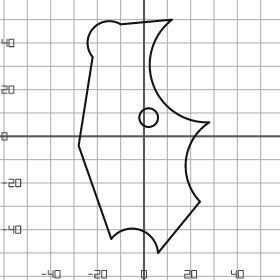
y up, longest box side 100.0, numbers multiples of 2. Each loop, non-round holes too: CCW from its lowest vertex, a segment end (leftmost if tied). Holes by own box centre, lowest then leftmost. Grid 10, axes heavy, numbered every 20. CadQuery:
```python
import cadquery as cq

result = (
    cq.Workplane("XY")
    .moveTo(6.0, -50.0)
    .lineTo(24.0, -28.0)
    .threePointArc((18.0, -10.0), (28.0, 6.0))
    .threePointArc((4.0, 22.0), (12.0, 50.0))
    .lineTo(-10.0, 48.0)
    .threePointArc((-22.0, 46.0), (-22.0, 34.0))
    .lineTo(-28.0, -4.0)
    .lineTo(-14.0, -44.0)
    .threePointArc((-2.0, -40.0), (6.0, -50.0))
    .close()
    .moveTo(2.0, 8.0)
    .circle(4.0)
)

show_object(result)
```